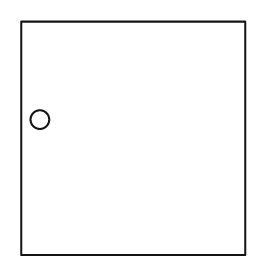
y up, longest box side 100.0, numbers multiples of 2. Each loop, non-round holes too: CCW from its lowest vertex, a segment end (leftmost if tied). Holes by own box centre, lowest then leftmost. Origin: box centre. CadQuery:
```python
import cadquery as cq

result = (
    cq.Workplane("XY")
    .moveTo(-48.0, -50.0)
    .lineTo(48.0, -50.0)
    .lineTo(48.0, 50.0)
    .lineTo(-48.0, 50.0)
    .close()
    .moveTo(-40.0, 8.0)
    .circle(4.0)
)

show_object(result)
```